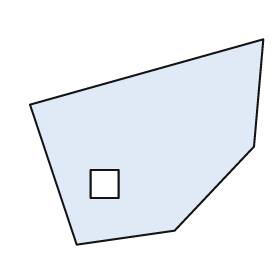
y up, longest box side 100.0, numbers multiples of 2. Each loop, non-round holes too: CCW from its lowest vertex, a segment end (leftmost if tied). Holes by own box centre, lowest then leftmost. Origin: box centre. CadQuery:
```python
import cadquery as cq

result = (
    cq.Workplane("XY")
    .moveTo(-30.0, -44.0)
    .lineTo(12.0, -38.0)
    .lineTo(46.0, -2.0)
    .lineTo(50.0, 44.0)
    .lineTo(-50.0, 16.0)
    .close()
    .moveTo(-24.0, -24.0)
    .lineTo(-12.0, -24.0)
    .lineTo(-12.0, -12.0)
    .lineTo(-24.0, -12.0)
    .close()
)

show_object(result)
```